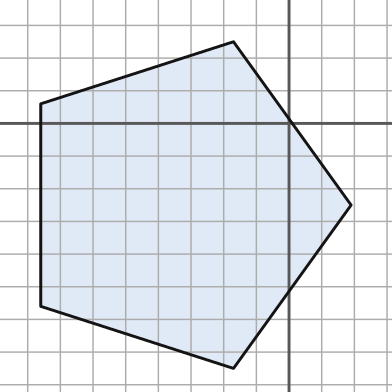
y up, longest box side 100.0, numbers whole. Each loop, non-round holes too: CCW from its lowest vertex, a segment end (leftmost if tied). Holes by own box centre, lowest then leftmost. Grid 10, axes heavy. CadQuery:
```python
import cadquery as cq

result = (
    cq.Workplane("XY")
    .moveTo(-17.0, -75.0)
    .lineTo(19.0, -25.0)
    .lineTo(-17.0, 25.0)
    .lineTo(-76.0, 6.0)
    .lineTo(-76.0, -56.0)
    .close()
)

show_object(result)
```